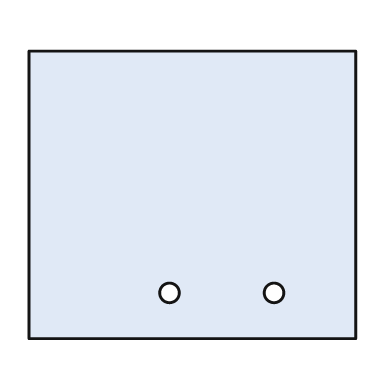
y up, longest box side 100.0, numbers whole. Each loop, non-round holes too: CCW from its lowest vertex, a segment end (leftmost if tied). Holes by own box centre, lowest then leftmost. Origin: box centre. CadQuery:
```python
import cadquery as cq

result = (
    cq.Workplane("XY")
    .moveTo(-50.0, -44.0)
    .lineTo(50.0, -44.0)
    .lineTo(50.0, 44.0)
    .lineTo(-50.0, 44.0)
    .close()
    .moveTo(-7.0, -30.0)
    .circle(3.0)
    .moveTo(25.0, -30.0)
    .circle(3.0)
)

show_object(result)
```